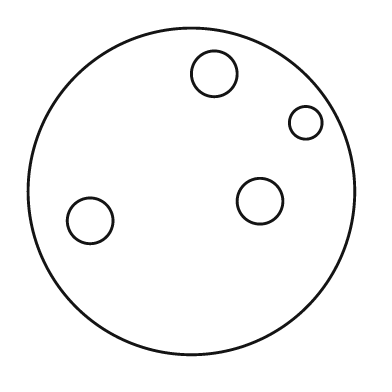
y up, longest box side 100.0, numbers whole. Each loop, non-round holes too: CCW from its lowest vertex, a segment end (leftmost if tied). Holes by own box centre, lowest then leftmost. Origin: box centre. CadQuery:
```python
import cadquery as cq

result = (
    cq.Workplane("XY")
    .moveTo(0.0, 0.0)
    .circle(50.0)
    .moveTo(-31.0, -9.0)
    .circle(7.0)
    .moveTo(21.0, -3.0)
    .circle(7.0)
    .moveTo(35.0, 21.0)
    .circle(5.0)
    .moveTo(7.0, 36.0)
    .circle(7.0)
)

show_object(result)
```